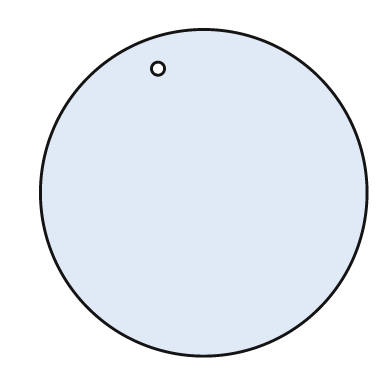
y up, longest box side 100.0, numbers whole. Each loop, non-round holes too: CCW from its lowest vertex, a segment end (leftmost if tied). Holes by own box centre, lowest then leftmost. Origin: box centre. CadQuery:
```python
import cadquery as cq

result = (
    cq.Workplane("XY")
    .moveTo(0.0, 0.0)
    .circle(50.0)
    .moveTo(-14.0, 38.0)
    .circle(2.0)
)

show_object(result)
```